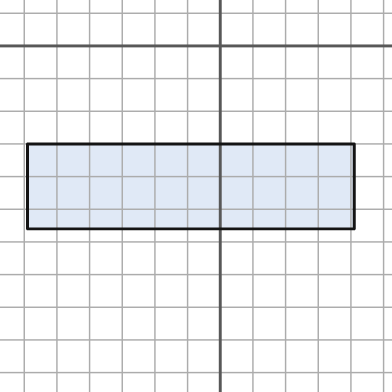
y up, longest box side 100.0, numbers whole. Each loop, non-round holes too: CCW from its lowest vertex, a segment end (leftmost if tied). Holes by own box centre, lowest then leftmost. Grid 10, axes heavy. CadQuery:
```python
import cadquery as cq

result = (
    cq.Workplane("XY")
    .moveTo(-59.0, -56.0)
    .lineTo(41.0, -56.0)
    .lineTo(41.0, -30.0)
    .lineTo(-59.0, -30.0)
    .close()
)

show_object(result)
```